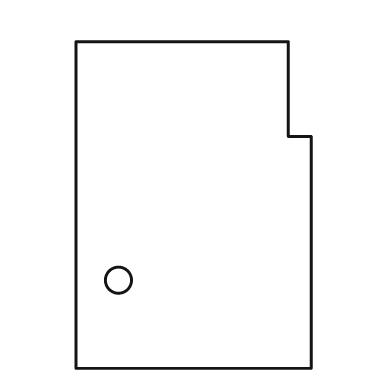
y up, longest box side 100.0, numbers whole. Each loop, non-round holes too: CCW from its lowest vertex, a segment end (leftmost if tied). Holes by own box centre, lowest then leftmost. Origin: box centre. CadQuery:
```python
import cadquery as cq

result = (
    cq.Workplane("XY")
    .moveTo(-36.0, -50.0)
    .lineTo(36.0, -50.0)
    .lineTo(36.0, 21.0)
    .lineTo(29.0, 21.0)
    .lineTo(29.0, 50.0)
    .lineTo(-36.0, 50.0)
    .close()
    .moveTo(-23.0, -23.0)
    .circle(4.0)
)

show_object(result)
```